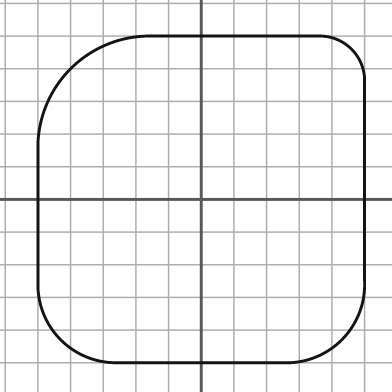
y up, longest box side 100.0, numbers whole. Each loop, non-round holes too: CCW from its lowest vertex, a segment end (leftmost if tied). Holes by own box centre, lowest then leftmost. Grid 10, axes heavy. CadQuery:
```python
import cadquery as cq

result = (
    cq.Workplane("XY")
    .moveTo(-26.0, -50.0)
    .lineTo(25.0, -50.0)
    .threePointArc((43.0, -43.0), (50.0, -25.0))
    .lineTo(50.0, 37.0)
    .threePointArc((46.0, 46.0), (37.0, 50.0))
    .lineTo(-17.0, 50.0)
    .threePointArc((-40.0, 40.0), (-50.0, 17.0))
    .lineTo(-50.0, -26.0)
    .threePointArc((-43.0, -43.0), (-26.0, -50.0))
    .close()
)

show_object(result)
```